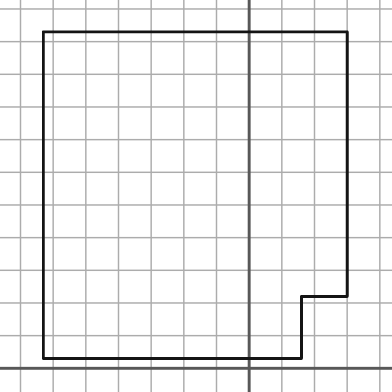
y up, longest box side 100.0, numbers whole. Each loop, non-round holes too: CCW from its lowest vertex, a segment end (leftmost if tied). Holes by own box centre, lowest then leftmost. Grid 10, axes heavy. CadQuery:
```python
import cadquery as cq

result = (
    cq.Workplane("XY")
    .moveTo(-63.0, 3.0)
    .lineTo(16.0, 3.0)
    .lineTo(16.0, 22.0)
    .lineTo(30.0, 22.0)
    .lineTo(30.0, 103.0)
    .lineTo(-63.0, 103.0)
    .close()
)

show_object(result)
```